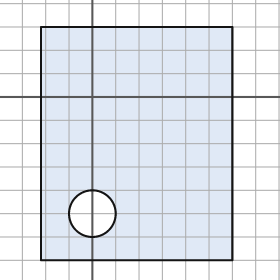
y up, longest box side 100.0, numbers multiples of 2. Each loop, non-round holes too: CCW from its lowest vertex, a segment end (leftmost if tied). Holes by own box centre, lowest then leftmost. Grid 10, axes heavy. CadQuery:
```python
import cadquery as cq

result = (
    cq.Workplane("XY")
    .moveTo(-22.0, -70.0)
    .lineTo(60.0, -70.0)
    .lineTo(60.0, 30.0)
    .lineTo(-22.0, 30.0)
    .close()
    .moveTo(0.0, -50.0)
    .circle(10.0)
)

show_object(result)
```